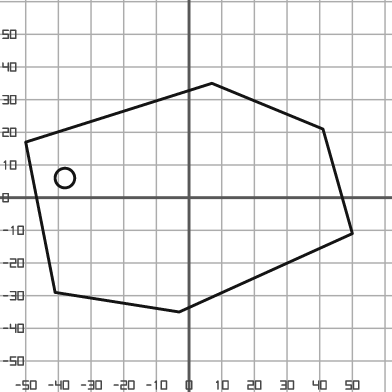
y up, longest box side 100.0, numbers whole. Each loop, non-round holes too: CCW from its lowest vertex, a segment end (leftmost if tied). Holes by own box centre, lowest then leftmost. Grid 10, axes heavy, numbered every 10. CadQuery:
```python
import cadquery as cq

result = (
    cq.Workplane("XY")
    .moveTo(-3.0, -35.0)
    .lineTo(50.0, -11.0)
    .lineTo(41.0, 21.0)
    .lineTo(7.0, 35.0)
    .lineTo(-50.0, 17.0)
    .lineTo(-41.0, -29.0)
    .close()
    .moveTo(-38.0, 6.0)
    .circle(3.0)
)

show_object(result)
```